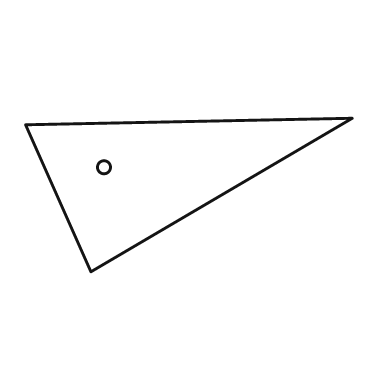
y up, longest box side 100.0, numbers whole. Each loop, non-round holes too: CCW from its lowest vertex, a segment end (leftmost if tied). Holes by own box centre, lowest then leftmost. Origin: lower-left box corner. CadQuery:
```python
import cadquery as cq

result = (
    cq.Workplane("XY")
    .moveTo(20.0, 0.0)
    .lineTo(100.0, 47.0)
    .lineTo(0.0, 45.0)
    .close()
    .moveTo(24.0, 32.0)
    .circle(2.0)
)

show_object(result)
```